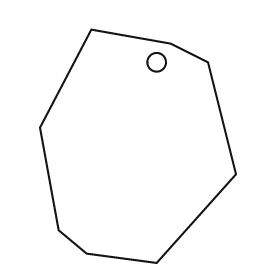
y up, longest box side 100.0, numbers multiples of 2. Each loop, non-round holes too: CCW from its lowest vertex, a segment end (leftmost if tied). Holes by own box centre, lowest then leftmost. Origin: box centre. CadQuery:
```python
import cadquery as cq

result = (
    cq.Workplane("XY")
    .moveTo(8.0, -50.0)
    .lineTo(42.0, -12.0)
    .lineTo(30.0, 36.0)
    .lineTo(14.0, 44.0)
    .lineTo(-20.0, 50.0)
    .lineTo(-42.0, 8.0)
    .lineTo(-34.0, -36.0)
    .lineTo(-22.0, -46.0)
    .close()
    .moveTo(8.0, 36.0)
    .circle(4.0)
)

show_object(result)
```